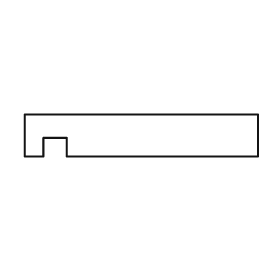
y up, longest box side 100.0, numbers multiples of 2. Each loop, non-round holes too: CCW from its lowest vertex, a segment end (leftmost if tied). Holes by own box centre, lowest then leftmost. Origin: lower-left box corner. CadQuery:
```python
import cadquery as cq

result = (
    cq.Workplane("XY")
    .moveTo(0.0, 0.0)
    .lineTo(8.0, 0.0)
    .lineTo(8.0, 8.0)
    .lineTo(18.0, 8.0)
    .lineTo(18.0, 0.0)
    .lineTo(100.0, 0.0)
    .lineTo(100.0, 18.0)
    .lineTo(0.0, 18.0)
    .close()
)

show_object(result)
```